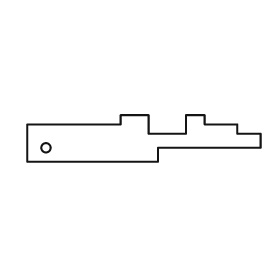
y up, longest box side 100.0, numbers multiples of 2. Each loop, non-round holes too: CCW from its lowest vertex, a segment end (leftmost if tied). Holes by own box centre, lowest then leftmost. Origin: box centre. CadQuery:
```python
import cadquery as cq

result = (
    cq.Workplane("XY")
    .moveTo(-50.0, -10.0)
    .lineTo(6.0, -10.0)
    .lineTo(6.0, -4.0)
    .lineTo(50.0, -4.0)
    .lineTo(50.0, 2.0)
    .lineTo(40.0, 2.0)
    .lineTo(40.0, 6.0)
    .lineTo(26.0, 6.0)
    .lineTo(26.0, 10.0)
    .lineTo(18.0, 10.0)
    .lineTo(18.0, 2.0)
    .lineTo(2.0, 2.0)
    .lineTo(2.0, 10.0)
    .lineTo(-10.0, 10.0)
    .lineTo(-10.0, 6.0)
    .lineTo(-50.0, 6.0)
    .close()
    .moveTo(-42.0, -4.0)
    .circle(2.0)
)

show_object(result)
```